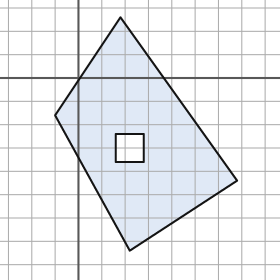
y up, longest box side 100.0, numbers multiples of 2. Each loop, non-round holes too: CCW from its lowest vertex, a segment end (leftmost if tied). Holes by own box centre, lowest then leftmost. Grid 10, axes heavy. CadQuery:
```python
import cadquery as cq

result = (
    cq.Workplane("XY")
    .moveTo(22.0, -74.0)
    .lineTo(68.0, -44.0)
    .lineTo(18.0, 26.0)
    .lineTo(-10.0, -16.0)
    .close()
    .moveTo(16.0, -36.0)
    .lineTo(28.0, -36.0)
    .lineTo(28.0, -24.0)
    .lineTo(16.0, -24.0)
    .close()
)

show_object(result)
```